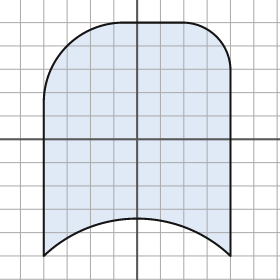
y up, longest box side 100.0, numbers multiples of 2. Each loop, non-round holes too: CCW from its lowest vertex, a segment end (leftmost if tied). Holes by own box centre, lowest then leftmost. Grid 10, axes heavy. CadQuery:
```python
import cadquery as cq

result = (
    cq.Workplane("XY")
    .moveTo(-40.0, -50.0)
    .threePointArc((0.0, -34.0), (40.0, -50.0))
    .lineTo(40.0, 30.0)
    .threePointArc((34.0, 44.0), (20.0, 50.0))
    .lineTo(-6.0, 50.0)
    .threePointArc((-30.0, 40.0), (-40.0, 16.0))
    .close()
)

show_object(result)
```